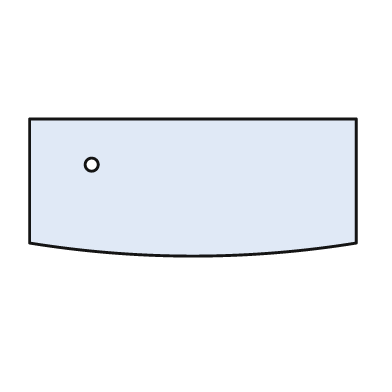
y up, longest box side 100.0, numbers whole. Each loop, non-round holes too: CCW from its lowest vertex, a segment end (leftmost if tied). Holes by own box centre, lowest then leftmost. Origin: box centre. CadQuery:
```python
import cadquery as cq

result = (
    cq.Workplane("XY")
    .moveTo(-50.0, -17.0)
    .threePointArc((0.0, -21.0), (50.0, -17.0))
    .lineTo(50.0, 21.0)
    .lineTo(-50.0, 21.0)
    .close()
    .moveTo(-31.0, 7.0)
    .circle(2.0)
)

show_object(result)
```